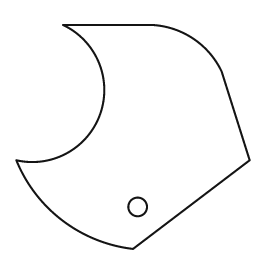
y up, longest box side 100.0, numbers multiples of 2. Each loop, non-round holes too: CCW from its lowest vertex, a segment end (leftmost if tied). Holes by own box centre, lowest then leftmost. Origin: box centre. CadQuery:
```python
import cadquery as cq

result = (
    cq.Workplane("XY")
    .moveTo(0.0, -48.0)
    .lineTo(50.0, -10.0)
    .lineTo(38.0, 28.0)
    .threePointArc((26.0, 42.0), (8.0, 48.0))
    .lineTo(-30.0, 48.0)
    .threePointArc((-14.0, 10.0), (-50.0, -10.0))
    .threePointArc((-30.0, -36.0), (0.0, -48.0))
    .close()
    .moveTo(2.0, -30.0)
    .circle(4.0)
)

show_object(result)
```